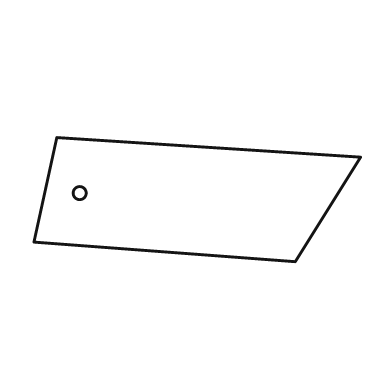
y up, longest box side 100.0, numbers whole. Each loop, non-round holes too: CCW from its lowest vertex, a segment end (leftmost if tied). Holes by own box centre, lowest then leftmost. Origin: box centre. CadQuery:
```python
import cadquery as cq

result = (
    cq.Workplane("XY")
    .moveTo(30.0, -19.0)
    .lineTo(50.0, 13.0)
    .lineTo(-43.0, 19.0)
    .lineTo(-50.0, -13.0)
    .close()
    .moveTo(-36.0, 2.0)
    .circle(2.0)
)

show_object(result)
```